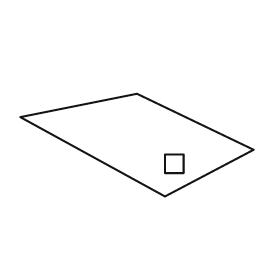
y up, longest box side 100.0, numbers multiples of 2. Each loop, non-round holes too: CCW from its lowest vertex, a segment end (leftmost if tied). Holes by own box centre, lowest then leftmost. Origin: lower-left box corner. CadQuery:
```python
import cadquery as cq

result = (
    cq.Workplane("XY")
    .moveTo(62.0, 0.0)
    .lineTo(100.0, 20.0)
    .lineTo(50.0, 44.0)
    .lineTo(0.0, 34.0)
    .close()
    .moveTo(62.0, 10.0)
    .lineTo(70.0, 10.0)
    .lineTo(70.0, 18.0)
    .lineTo(62.0, 18.0)
    .close()
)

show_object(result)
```